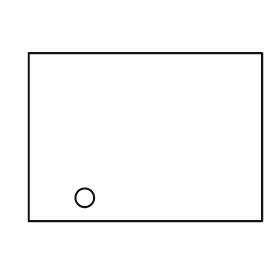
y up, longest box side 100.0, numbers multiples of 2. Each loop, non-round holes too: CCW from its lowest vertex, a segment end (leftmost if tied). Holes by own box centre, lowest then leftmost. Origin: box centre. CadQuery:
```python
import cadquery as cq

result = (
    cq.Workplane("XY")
    .moveTo(-50.0, -36.0)
    .lineTo(50.0, -36.0)
    .lineTo(50.0, 36.0)
    .lineTo(-50.0, 36.0)
    .close()
    .moveTo(-26.0, -26.0)
    .circle(4.0)
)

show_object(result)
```